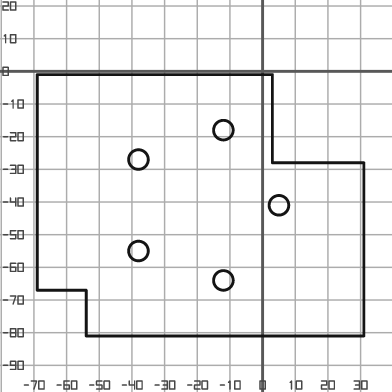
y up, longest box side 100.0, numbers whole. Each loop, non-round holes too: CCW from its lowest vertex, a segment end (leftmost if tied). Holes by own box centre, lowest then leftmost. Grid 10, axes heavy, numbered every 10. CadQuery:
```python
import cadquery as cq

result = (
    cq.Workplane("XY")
    .moveTo(-54.0, -81.0)
    .lineTo(31.0, -81.0)
    .lineTo(31.0, -28.0)
    .lineTo(3.0, -28.0)
    .lineTo(3.0, -1.0)
    .lineTo(-69.0, -1.0)
    .lineTo(-69.0, -67.0)
    .lineTo(-54.0, -67.0)
    .close()
    .moveTo(-12.0, -64.0)
    .circle(3.0)
    .moveTo(-38.0, -55.0)
    .circle(3.0)
    .moveTo(5.0, -41.0)
    .circle(3.0)
    .moveTo(-38.0, -27.0)
    .circle(3.0)
    .moveTo(-12.0, -18.0)
    .circle(3.0)
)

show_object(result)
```